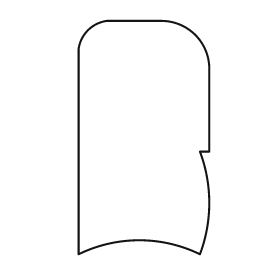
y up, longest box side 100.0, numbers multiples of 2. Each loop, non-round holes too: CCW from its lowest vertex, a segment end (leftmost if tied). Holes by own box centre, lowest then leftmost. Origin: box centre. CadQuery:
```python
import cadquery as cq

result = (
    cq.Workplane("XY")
    .moveTo(-28.0, -50.0)
    .threePointArc((-2.0, -44.0), (24.0, -50.0))
    .threePointArc((28.0, -28.0), (24.0, -6.0))
    .lineTo(28.0, -6.0)
    .lineTo(28.0, 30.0)
    .threePointArc((22.0, 44.0), (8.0, 50.0))
    .lineTo(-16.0, 50.0)
    .threePointArc((-24.0, 46.0), (-28.0, 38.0))
    .close()
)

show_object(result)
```